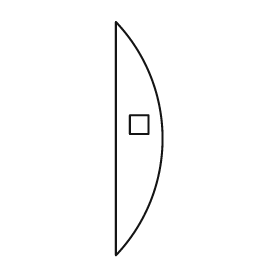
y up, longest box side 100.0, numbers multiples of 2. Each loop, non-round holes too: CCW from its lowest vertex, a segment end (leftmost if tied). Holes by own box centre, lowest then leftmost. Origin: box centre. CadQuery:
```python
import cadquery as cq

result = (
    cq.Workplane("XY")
    .moveTo(-10.0, -50.0)
    .threePointArc((10.0, 0.0), (-10.0, 50.0))
    .close()
    .moveTo(-4.0, 2.0)
    .lineTo(4.0, 2.0)
    .lineTo(4.0, 10.0)
    .lineTo(-4.0, 10.0)
    .close()
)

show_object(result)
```